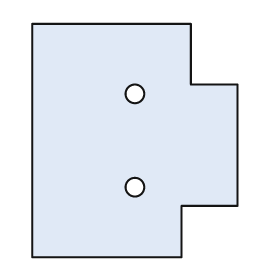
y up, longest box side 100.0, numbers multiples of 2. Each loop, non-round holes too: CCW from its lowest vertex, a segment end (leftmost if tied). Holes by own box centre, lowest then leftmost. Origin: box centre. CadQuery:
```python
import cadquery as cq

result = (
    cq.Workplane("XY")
    .moveTo(-44.0, -50.0)
    .lineTo(20.0, -50.0)
    .lineTo(20.0, -28.0)
    .lineTo(44.0, -28.0)
    .lineTo(44.0, 24.0)
    .lineTo(24.0, 24.0)
    .lineTo(24.0, 50.0)
    .lineTo(-44.0, 50.0)
    .close()
    .moveTo(0.0, -20.0)
    .circle(4.0)
    .moveTo(0.0, 20.0)
    .circle(4.0)
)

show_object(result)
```